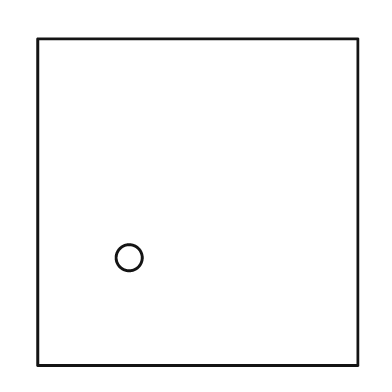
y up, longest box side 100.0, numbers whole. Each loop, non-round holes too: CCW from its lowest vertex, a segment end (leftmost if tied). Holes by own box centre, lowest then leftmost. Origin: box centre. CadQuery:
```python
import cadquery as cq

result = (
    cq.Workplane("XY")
    .moveTo(-49.0, -50.0)
    .lineTo(49.0, -50.0)
    .lineTo(49.0, 50.0)
    .lineTo(-49.0, 50.0)
    .close()
    .moveTo(-21.0, -17.0)
    .circle(4.0)
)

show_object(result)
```